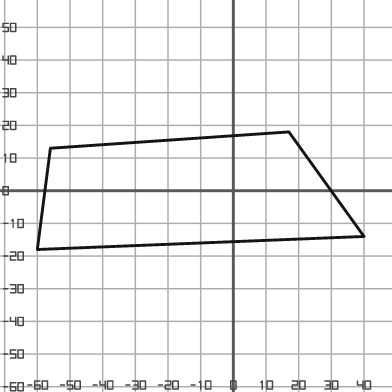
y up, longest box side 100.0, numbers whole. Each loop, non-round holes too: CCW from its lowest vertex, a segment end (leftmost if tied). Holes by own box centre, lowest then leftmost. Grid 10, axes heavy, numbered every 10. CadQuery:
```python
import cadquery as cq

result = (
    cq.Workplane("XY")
    .moveTo(-60.0, -18.0)
    .lineTo(40.0, -14.0)
    .lineTo(17.0, 18.0)
    .lineTo(-56.0, 13.0)
    .close()
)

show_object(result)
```